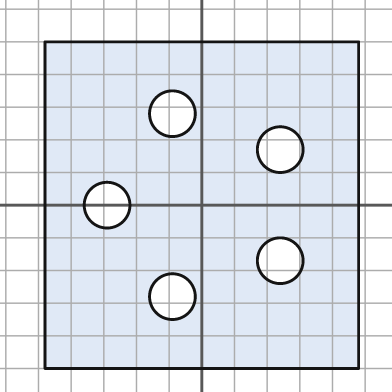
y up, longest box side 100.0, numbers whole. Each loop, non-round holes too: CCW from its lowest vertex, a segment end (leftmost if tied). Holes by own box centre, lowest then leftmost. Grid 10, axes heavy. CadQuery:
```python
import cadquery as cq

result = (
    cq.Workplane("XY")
    .moveTo(-48.0, -50.0)
    .lineTo(48.0, -50.0)
    .lineTo(48.0, 50.0)
    .lineTo(-48.0, 50.0)
    .close()
    .moveTo(-9.0, -28.0)
    .circle(7.0)
    .moveTo(24.0, -17.0)
    .circle(7.0)
    .moveTo(-29.0, 0.0)
    .circle(7.0)
    .moveTo(24.0, 17.0)
    .circle(7.0)
    .moveTo(-9.0, 28.0)
    .circle(7.0)
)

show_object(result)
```